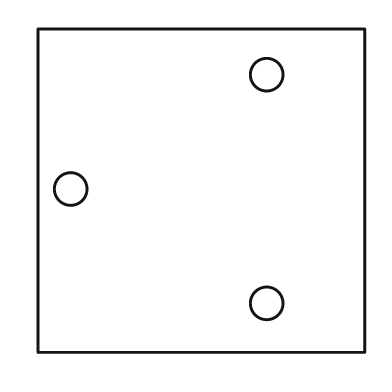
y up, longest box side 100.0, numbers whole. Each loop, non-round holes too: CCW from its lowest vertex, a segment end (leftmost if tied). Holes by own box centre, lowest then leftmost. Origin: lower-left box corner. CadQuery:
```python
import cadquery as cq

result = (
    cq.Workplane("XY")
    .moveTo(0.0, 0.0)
    .lineTo(100.0, 0.0)
    .lineTo(100.0, 99.0)
    .lineTo(0.0, 99.0)
    .close()
    .moveTo(70.0, 15.0)
    .circle(5.0)
    .moveTo(10.0, 50.0)
    .circle(5.0)
    .moveTo(70.0, 85.0)
    .circle(5.0)
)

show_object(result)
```